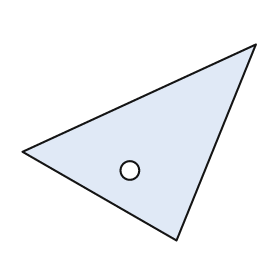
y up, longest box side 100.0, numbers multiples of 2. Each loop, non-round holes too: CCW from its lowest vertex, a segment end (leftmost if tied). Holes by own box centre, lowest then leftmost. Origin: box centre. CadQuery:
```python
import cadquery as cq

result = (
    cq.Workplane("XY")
    .moveTo(16.0, -42.0)
    .lineTo(50.0, 42.0)
    .lineTo(-50.0, -4.0)
    .close()
    .moveTo(-4.0, -12.0)
    .circle(4.0)
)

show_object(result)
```